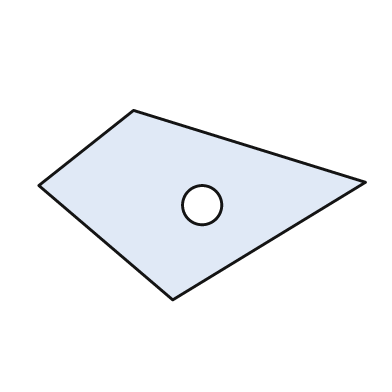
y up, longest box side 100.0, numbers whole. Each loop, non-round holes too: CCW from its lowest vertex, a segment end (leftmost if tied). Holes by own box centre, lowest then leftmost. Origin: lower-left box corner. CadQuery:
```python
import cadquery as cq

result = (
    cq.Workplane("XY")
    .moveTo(41.0, 0.0)
    .lineTo(100.0, 36.0)
    .lineTo(29.0, 58.0)
    .lineTo(0.0, 35.0)
    .close()
    .moveTo(50.0, 29.0)
    .circle(6.0)
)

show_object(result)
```